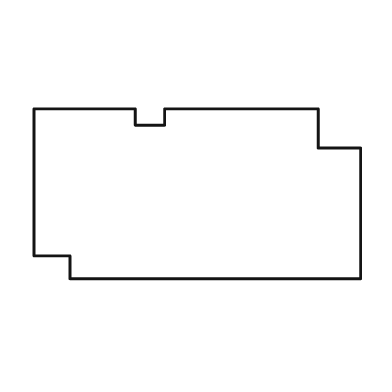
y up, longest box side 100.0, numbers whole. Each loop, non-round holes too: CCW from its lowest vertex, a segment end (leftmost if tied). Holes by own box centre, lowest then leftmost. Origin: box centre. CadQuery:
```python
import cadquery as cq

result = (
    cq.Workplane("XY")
    .moveTo(-39.0, -26.0)
    .lineTo(50.0, -26.0)
    .lineTo(50.0, 14.0)
    .lineTo(37.0, 14.0)
    .lineTo(37.0, 26.0)
    .lineTo(-10.0, 26.0)
    .lineTo(-10.0, 21.0)
    .lineTo(-19.0, 21.0)
    .lineTo(-19.0, 26.0)
    .lineTo(-50.0, 26.0)
    .lineTo(-50.0, -19.0)
    .lineTo(-39.0, -19.0)
    .close()
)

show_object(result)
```